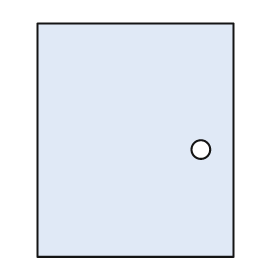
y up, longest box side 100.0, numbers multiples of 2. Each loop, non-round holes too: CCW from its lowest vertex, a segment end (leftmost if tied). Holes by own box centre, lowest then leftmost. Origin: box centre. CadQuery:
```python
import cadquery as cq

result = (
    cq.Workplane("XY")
    .moveTo(-42.0, -50.0)
    .lineTo(42.0, -50.0)
    .lineTo(42.0, 50.0)
    .lineTo(-42.0, 50.0)
    .close()
    .moveTo(28.0, -4.0)
    .circle(4.0)
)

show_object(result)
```